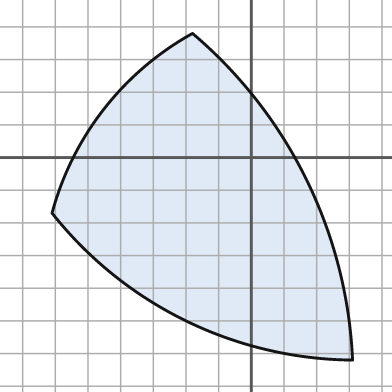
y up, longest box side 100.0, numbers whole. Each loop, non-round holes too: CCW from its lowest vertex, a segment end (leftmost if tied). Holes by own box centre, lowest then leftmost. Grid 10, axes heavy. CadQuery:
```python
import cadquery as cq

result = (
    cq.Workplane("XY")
    .moveTo(31.0, -62.0)
    .threePointArc((17.0, -7.0), (-18.0, 38.0))
    .threePointArc((-45.0, 15.0), (-61.0, -17.0))
    .threePointArc((-20.0, -50.0), (31.0, -62.0))
    .close()
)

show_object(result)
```